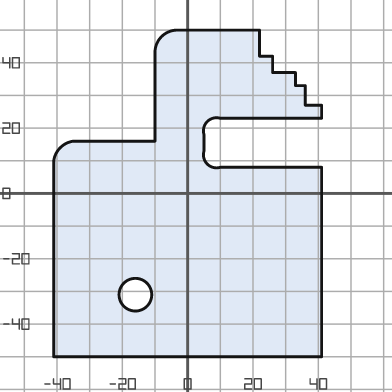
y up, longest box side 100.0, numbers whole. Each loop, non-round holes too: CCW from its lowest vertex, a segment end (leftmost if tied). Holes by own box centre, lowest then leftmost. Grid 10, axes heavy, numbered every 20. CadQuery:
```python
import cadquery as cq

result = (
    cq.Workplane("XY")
    .moveTo(-41.0, -50.0)
    .lineTo(41.0, -50.0)
    .lineTo(41.0, 8.0)
    .lineTo(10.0, 8.0)
    .threePointArc((6.0, 9.0), (5.0, 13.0))
    .lineTo(5.0, 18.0)
    .threePointArc((6.0, 22.0), (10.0, 23.0))
    .lineTo(41.0, 23.0)
    .lineTo(41.0, 27.0)
    .lineTo(36.0, 27.0)
    .lineTo(36.0, 33.0)
    .lineTo(33.0, 33.0)
    .lineTo(33.0, 37.0)
    .lineTo(26.0, 37.0)
    .lineTo(26.0, 42.0)
    .lineTo(22.0, 42.0)
    .lineTo(22.0, 50.0)
    .lineTo(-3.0, 50.0)
    .threePointArc((-8.0, 48.0), (-10.0, 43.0))
    .lineTo(-10.0, 16.0)
    .lineTo(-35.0, 16.0)
    .threePointArc((-39.0, 14.0), (-41.0, 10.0))
    .close()
    .moveTo(-16.0, -31.0)
    .circle(5.0)
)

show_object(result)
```